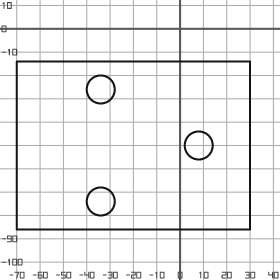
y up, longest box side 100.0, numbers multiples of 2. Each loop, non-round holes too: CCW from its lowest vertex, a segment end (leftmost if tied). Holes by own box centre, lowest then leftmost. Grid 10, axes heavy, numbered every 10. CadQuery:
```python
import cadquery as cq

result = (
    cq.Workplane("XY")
    .moveTo(-70.0, -86.0)
    .lineTo(30.0, -86.0)
    .lineTo(30.0, -14.0)
    .lineTo(-70.0, -14.0)
    .close()
    .moveTo(-34.0, -74.0)
    .circle(6.0)
    .moveTo(8.0, -50.0)
    .circle(6.0)
    .moveTo(-34.0, -26.0)
    .circle(6.0)
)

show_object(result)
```